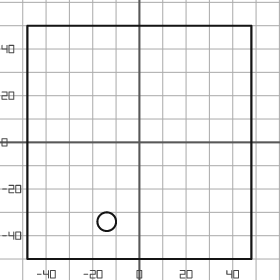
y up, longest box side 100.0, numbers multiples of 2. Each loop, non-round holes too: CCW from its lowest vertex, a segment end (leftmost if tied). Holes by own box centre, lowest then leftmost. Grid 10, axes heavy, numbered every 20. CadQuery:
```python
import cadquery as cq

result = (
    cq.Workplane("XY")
    .moveTo(-48.0, -50.0)
    .lineTo(48.0, -50.0)
    .lineTo(48.0, 50.0)
    .lineTo(-48.0, 50.0)
    .close()
    .moveTo(-14.0, -34.0)
    .circle(4.0)
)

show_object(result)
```